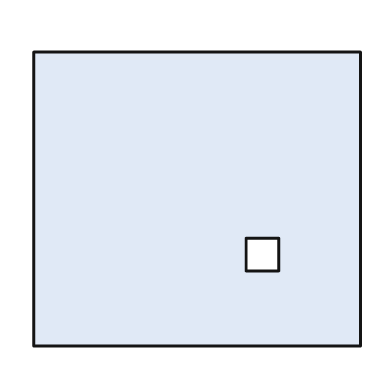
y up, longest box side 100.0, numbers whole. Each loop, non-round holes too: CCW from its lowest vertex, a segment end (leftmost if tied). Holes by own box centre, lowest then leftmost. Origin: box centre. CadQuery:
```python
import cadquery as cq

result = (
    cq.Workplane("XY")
    .moveTo(-50.0, -45.0)
    .lineTo(50.0, -45.0)
    .lineTo(50.0, 45.0)
    .lineTo(-50.0, 45.0)
    .close()
    .moveTo(15.0, -22.0)
    .lineTo(25.0, -22.0)
    .lineTo(25.0, -12.0)
    .lineTo(15.0, -12.0)
    .close()
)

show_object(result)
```